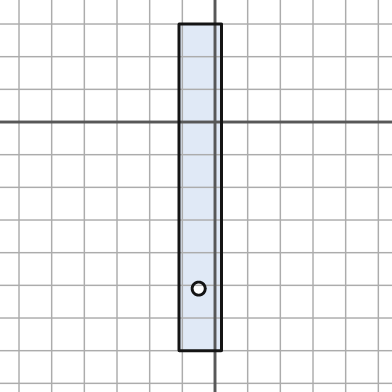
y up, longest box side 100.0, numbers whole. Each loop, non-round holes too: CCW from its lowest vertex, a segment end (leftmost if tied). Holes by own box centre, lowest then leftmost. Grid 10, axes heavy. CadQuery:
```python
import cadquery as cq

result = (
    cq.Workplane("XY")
    .moveTo(-11.0, -70.0)
    .lineTo(2.0, -70.0)
    .lineTo(2.0, 30.0)
    .lineTo(-11.0, 30.0)
    .close()
    .moveTo(-5.0, -51.0)
    .circle(2.0)
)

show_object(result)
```